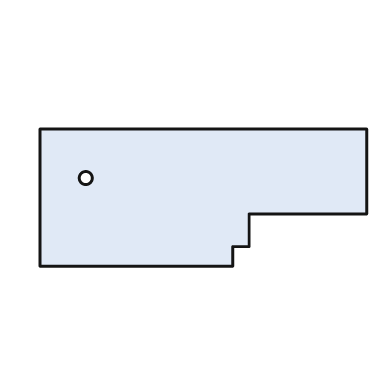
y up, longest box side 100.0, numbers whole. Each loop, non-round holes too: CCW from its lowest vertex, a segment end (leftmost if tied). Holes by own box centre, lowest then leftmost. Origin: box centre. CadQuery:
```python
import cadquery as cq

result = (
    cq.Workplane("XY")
    .moveTo(-50.0, -21.0)
    .lineTo(9.0, -21.0)
    .lineTo(9.0, -15.0)
    .lineTo(14.0, -15.0)
    .lineTo(14.0, -5.0)
    .lineTo(50.0, -5.0)
    .lineTo(50.0, 21.0)
    .lineTo(-50.0, 21.0)
    .close()
    .moveTo(-36.0, 6.0)
    .circle(2.0)
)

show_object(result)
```